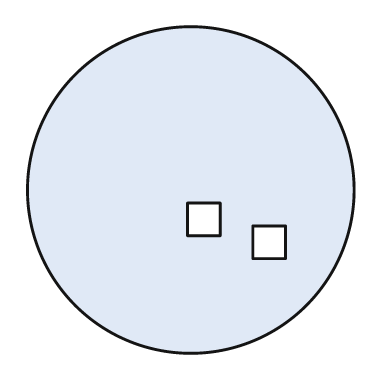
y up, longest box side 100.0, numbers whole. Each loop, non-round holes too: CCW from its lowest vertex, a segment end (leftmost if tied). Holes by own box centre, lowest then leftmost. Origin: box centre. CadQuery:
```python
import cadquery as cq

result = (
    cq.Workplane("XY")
    .moveTo(0.0, 0.0)
    .circle(50.0)
    .moveTo(19.0, -21.0)
    .lineTo(29.0, -21.0)
    .lineTo(29.0, -11.0)
    .lineTo(19.0, -11.0)
    .close()
    .moveTo(-1.0, -14.0)
    .lineTo(9.0, -14.0)
    .lineTo(9.0, -4.0)
    .lineTo(-1.0, -4.0)
    .close()
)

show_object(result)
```